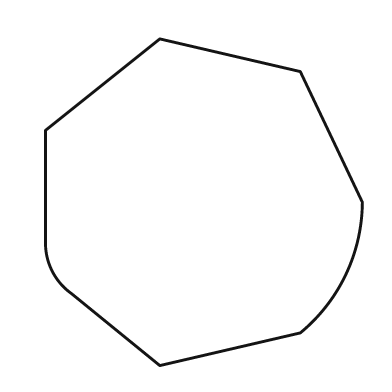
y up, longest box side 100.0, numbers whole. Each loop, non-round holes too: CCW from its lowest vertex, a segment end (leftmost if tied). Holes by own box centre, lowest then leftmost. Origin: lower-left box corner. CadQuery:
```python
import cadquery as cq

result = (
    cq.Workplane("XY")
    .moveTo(35.0, 0.0)
    .lineTo(78.0, 10.0)
    .threePointArc((92.0, 28.0), (97.0, 50.0))
    .lineTo(78.0, 90.0)
    .lineTo(35.0, 100.0)
    .lineTo(0.0, 72.0)
    .lineTo(0.0, 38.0)
    .threePointArc((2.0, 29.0), (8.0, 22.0))
    .close()
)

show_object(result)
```